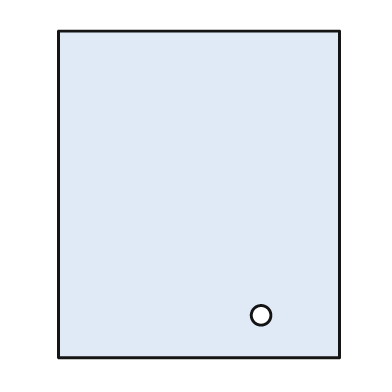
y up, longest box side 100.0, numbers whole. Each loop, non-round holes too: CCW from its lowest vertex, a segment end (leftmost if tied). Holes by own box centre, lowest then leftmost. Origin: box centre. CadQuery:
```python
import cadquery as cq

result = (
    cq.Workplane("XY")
    .moveTo(-43.0, -50.0)
    .lineTo(43.0, -50.0)
    .lineTo(43.0, 50.0)
    .lineTo(-43.0, 50.0)
    .close()
    .moveTo(19.0, -37.0)
    .circle(3.0)
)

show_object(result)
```